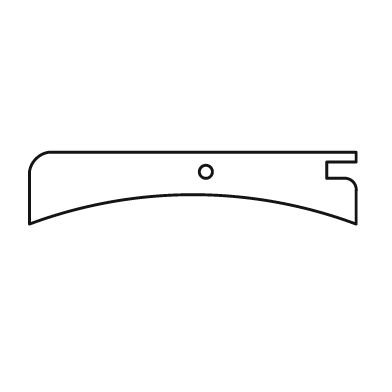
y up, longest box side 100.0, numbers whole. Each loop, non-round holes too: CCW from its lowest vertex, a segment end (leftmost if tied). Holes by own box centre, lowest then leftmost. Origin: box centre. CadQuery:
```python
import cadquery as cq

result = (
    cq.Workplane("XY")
    .moveTo(-50.0, -11.0)
    .threePointArc((0.0, -2.0), (50.0, -11.0))
    .lineTo(50.0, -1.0)
    .threePointArc((49.0, 2.0), (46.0, 3.0))
    .lineTo(41.0, 3.0)
    .lineTo(41.0, 8.0)
    .lineTo(50.0, 8.0)
    .lineTo(50.0, 11.0)
    .lineTo(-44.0, 11.0)
    .threePointArc((-48.0, 9.0), (-50.0, 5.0))
    .close()
    .moveTo(4.0, 5.0)
    .circle(2.0)
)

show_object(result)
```